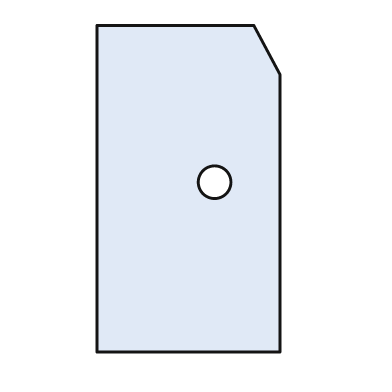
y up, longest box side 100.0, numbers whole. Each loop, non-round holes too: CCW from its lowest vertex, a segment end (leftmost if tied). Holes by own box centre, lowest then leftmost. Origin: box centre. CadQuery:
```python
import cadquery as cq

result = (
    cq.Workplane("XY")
    .moveTo(-28.0, -50.0)
    .lineTo(28.0, -50.0)
    .lineTo(28.0, 35.0)
    .lineTo(20.0, 50.0)
    .lineTo(-28.0, 50.0)
    .close()
    .moveTo(8.0, 2.0)
    .circle(5.0)
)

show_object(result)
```